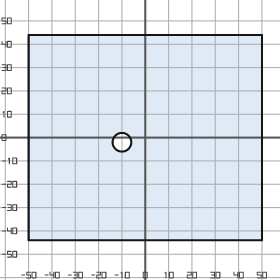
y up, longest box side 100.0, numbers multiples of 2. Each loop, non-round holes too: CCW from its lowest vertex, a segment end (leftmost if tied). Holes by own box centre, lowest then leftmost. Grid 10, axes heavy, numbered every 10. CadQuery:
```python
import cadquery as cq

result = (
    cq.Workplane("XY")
    .moveTo(-50.0, -44.0)
    .lineTo(50.0, -44.0)
    .lineTo(50.0, 44.0)
    .lineTo(-50.0, 44.0)
    .close()
    .moveTo(-10.0, -2.0)
    .circle(4.0)
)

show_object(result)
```